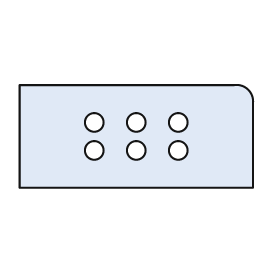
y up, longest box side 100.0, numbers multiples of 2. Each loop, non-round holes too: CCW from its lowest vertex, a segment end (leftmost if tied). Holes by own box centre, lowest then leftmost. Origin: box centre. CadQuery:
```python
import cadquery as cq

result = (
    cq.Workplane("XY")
    .moveTo(-50.0, -22.0)
    .lineTo(50.0, -22.0)
    .lineTo(50.0, 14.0)
    .threePointArc((48.0, 20.0), (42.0, 22.0))
    .lineTo(-50.0, 22.0)
    .close()
    .moveTo(-18.0, -6.0)
    .circle(4.0)
    .moveTo(0.0, -6.0)
    .circle(4.0)
    .moveTo(18.0, -6.0)
    .circle(4.0)
    .moveTo(-18.0, 6.0)
    .circle(4.0)
    .moveTo(0.0, 6.0)
    .circle(4.0)
    .moveTo(18.0, 6.0)
    .circle(4.0)
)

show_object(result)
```